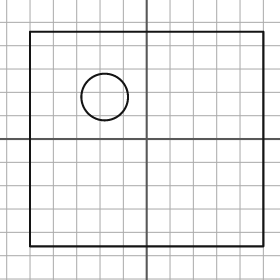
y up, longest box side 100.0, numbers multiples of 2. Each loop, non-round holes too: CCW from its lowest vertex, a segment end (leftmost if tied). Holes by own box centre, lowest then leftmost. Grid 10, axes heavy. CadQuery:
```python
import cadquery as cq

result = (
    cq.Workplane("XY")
    .moveTo(-50.0, -46.0)
    .lineTo(50.0, -46.0)
    .lineTo(50.0, 46.0)
    .lineTo(-50.0, 46.0)
    .close()
    .moveTo(-18.0, 18.0)
    .circle(10.0)
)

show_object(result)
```